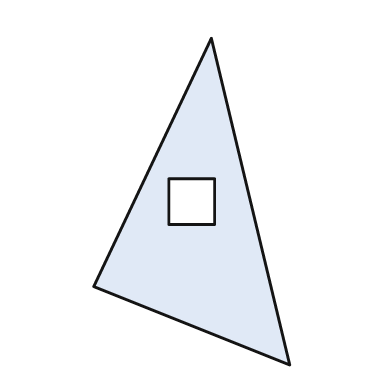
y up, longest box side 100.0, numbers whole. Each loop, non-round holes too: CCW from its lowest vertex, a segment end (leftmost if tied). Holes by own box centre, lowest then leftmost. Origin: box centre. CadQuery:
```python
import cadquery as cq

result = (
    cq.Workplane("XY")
    .moveTo(30.0, -50.0)
    .lineTo(6.0, 50.0)
    .lineTo(-30.0, -26.0)
    .close()
    .moveTo(-7.0, -7.0)
    .lineTo(7.0, -7.0)
    .lineTo(7.0, 7.0)
    .lineTo(-7.0, 7.0)
    .close()
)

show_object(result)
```